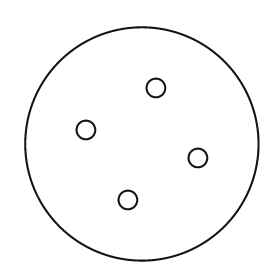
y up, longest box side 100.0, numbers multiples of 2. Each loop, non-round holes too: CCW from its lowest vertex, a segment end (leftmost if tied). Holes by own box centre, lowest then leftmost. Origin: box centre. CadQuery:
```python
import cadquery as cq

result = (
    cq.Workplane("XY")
    .moveTo(0.0, 0.0)
    .circle(50.0)
    .moveTo(-6.0, -24.0)
    .circle(4.0)
    .moveTo(24.0, -6.0)
    .circle(4.0)
    .moveTo(-24.0, 6.0)
    .circle(4.0)
    .moveTo(6.0, 24.0)
    .circle(4.0)
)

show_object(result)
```